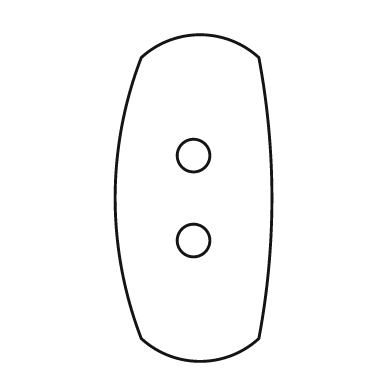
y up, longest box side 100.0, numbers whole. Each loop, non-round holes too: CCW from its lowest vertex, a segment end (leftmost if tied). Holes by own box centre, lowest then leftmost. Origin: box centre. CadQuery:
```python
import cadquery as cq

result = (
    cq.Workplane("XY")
    .moveTo(-16.0, -43.0)
    .threePointArc((2.0, -50.0), (20.0, -43.0))
    .threePointArc((24.0, 0.0), (20.0, 43.0))
    .threePointArc((2.0, 50.0), (-16.0, 43.0))
    .threePointArc((-24.0, 0.0), (-16.0, -43.0))
    .close()
    .moveTo(0.0, -13.0)
    .circle(5.0)
    .moveTo(0.0, 13.0)
    .circle(5.0)
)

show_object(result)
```